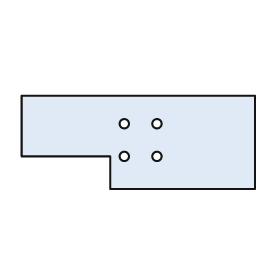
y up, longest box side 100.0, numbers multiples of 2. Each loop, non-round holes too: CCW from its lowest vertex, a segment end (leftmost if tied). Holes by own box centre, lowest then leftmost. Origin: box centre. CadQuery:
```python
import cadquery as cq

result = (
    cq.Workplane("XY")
    .moveTo(-12.0, -20.0)
    .lineTo(50.0, -20.0)
    .lineTo(50.0, 20.0)
    .lineTo(-50.0, 20.0)
    .lineTo(-50.0, -6.0)
    .lineTo(-12.0, -6.0)
    .close()
    .moveTo(-6.0, -6.0)
    .circle(2.0)
    .moveTo(8.0, -6.0)
    .circle(2.0)
    .moveTo(-6.0, 8.0)
    .circle(2.0)
    .moveTo(8.0, 8.0)
    .circle(2.0)
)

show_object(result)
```